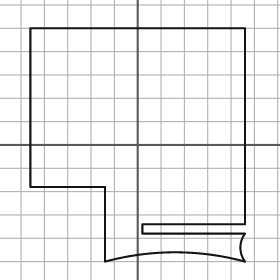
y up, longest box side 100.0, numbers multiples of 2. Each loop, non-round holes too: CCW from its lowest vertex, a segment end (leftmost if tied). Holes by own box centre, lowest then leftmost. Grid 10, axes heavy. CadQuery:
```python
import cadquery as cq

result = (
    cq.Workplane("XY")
    .moveTo(-14.0, -50.0)
    .threePointArc((16.0, -46.0), (46.0, -50.0))
    .threePointArc((44.0, -44.0), (46.0, -38.0))
    .lineTo(2.0, -38.0)
    .lineTo(2.0, -34.0)
    .lineTo(46.0, -34.0)
    .lineTo(46.0, 50.0)
    .lineTo(-46.0, 50.0)
    .lineTo(-46.0, -18.0)
    .lineTo(-14.0, -18.0)
    .close()
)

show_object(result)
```